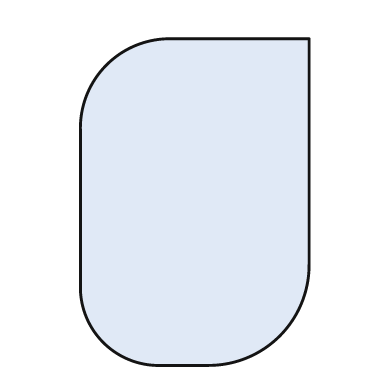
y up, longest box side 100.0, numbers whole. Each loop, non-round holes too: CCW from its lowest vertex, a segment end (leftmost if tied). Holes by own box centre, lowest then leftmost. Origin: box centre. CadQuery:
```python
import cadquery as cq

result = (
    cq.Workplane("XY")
    .moveTo(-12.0, -50.0)
    .lineTo(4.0, -50.0)
    .threePointArc((26.0, -41.0), (35.0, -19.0))
    .lineTo(35.0, 50.0)
    .lineTo(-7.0, 50.0)
    .threePointArc((-27.0, 42.0), (-35.0, 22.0))
    .lineTo(-35.0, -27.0)
    .threePointArc((-28.0, -43.0), (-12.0, -50.0))
    .close()
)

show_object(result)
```